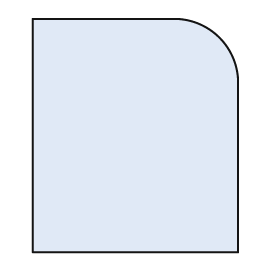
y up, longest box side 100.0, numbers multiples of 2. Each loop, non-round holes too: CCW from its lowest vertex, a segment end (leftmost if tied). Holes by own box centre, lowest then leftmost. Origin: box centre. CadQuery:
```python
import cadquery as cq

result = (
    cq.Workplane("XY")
    .moveTo(-44.0, -50.0)
    .lineTo(44.0, -50.0)
    .lineTo(44.0, 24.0)
    .threePointArc((36.0, 42.0), (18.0, 50.0))
    .lineTo(-44.0, 50.0)
    .close()
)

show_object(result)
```